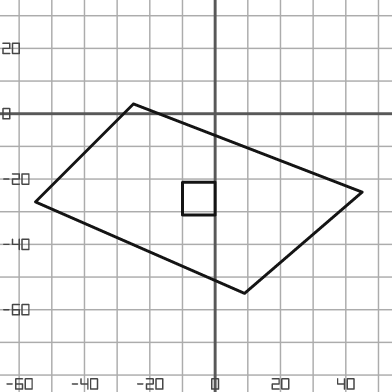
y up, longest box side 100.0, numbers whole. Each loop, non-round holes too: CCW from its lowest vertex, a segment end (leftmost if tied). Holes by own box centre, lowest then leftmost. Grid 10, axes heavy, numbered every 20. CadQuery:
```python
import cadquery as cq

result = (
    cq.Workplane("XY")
    .moveTo(9.0, -55.0)
    .lineTo(45.0, -24.0)
    .lineTo(-25.0, 3.0)
    .lineTo(-55.0, -27.0)
    .close()
    .moveTo(-10.0, -31.0)
    .lineTo(0.0, -31.0)
    .lineTo(0.0, -21.0)
    .lineTo(-10.0, -21.0)
    .close()
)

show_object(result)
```